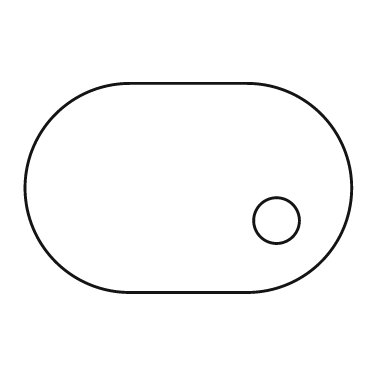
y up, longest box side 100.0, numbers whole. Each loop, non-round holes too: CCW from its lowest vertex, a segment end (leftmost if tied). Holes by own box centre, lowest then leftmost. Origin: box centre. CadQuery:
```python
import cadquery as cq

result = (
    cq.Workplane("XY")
    .moveTo(-18.0, -32.0)
    .lineTo(18.0, -32.0)
    .threePointArc((50.0, 0.0), (18.0, 32.0))
    .lineTo(-18.0, 32.0)
    .threePointArc((-50.0, 0.0), (-18.0, -32.0))
    .close()
    .moveTo(27.0, -10.0)
    .circle(7.0)
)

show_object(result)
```